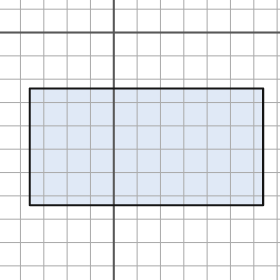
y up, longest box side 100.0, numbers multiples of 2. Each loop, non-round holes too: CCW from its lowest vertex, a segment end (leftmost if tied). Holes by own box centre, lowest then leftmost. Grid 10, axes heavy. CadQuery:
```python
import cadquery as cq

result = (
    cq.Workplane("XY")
    .moveTo(-36.0, -74.0)
    .lineTo(64.0, -74.0)
    .lineTo(64.0, -24.0)
    .lineTo(-36.0, -24.0)
    .close()
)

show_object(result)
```